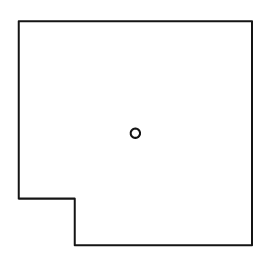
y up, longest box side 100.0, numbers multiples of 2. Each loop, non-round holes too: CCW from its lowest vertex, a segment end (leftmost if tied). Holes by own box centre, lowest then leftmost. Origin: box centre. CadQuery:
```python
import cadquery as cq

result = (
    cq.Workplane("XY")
    .moveTo(-26.0, -48.0)
    .lineTo(50.0, -48.0)
    .lineTo(50.0, 48.0)
    .lineTo(-50.0, 48.0)
    .lineTo(-50.0, -28.0)
    .lineTo(-26.0, -28.0)
    .close()
    .moveTo(0.0, 0.0)
    .circle(2.0)
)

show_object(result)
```